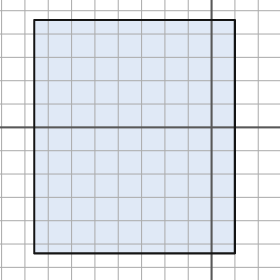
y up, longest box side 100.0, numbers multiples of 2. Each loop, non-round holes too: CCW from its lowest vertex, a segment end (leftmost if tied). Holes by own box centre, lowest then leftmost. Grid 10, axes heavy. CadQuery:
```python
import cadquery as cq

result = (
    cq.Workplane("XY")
    .moveTo(-76.0, -54.0)
    .lineTo(10.0, -54.0)
    .lineTo(10.0, 46.0)
    .lineTo(-76.0, 46.0)
    .close()
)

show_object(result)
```